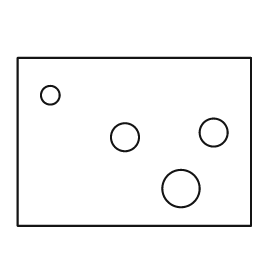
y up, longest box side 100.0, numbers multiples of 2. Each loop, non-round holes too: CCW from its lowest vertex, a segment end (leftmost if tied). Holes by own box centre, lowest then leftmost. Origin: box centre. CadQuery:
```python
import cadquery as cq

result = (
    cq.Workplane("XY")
    .moveTo(-50.0, -36.0)
    .lineTo(50.0, -36.0)
    .lineTo(50.0, 36.0)
    .lineTo(-50.0, 36.0)
    .close()
    .moveTo(20.0, -20.0)
    .circle(8.0)
    .moveTo(-4.0, 2.0)
    .circle(6.0)
    .moveTo(34.0, 4.0)
    .circle(6.0)
    .moveTo(-36.0, 20.0)
    .circle(4.0)
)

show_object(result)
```